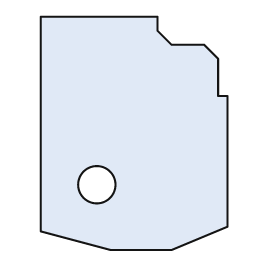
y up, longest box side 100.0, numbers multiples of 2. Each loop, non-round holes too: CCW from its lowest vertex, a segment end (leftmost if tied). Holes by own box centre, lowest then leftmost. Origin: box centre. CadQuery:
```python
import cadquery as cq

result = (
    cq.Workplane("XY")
    .moveTo(-10.0, -50.0)
    .lineTo(16.0, -50.0)
    .lineTo(40.0, -40.0)
    .lineTo(40.0, 16.0)
    .lineTo(36.0, 16.0)
    .lineTo(36.0, 32.0)
    .lineTo(30.0, 38.0)
    .lineTo(16.0, 38.0)
    .lineTo(10.0, 44.0)
    .lineTo(10.0, 50.0)
    .lineTo(-40.0, 50.0)
    .lineTo(-40.0, -42.0)
    .close()
    .moveTo(-16.0, -22.0)
    .circle(8.0)
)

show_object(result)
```